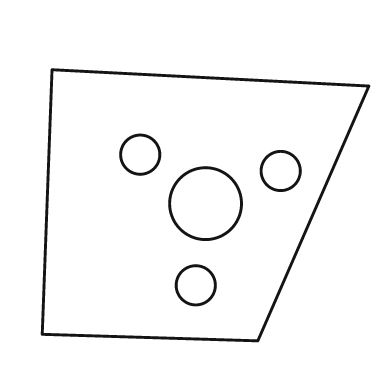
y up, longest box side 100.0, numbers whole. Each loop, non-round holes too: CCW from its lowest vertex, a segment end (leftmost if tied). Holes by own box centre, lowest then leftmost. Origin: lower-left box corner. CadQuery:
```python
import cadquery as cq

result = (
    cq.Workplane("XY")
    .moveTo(66.0, 0.0)
    .lineTo(100.0, 78.0)
    .lineTo(3.0, 83.0)
    .lineTo(0.0, 2.0)
    .close()
    .moveTo(47.0, 17.0)
    .circle(6.0)
    .moveTo(50.0, 42.0)
    .circle(11.0)
    .moveTo(73.0, 52.0)
    .circle(6.0)
    .moveTo(30.0, 57.0)
    .circle(6.0)
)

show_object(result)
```